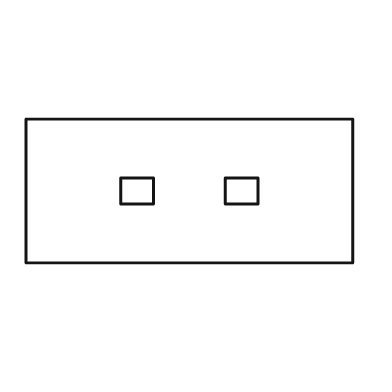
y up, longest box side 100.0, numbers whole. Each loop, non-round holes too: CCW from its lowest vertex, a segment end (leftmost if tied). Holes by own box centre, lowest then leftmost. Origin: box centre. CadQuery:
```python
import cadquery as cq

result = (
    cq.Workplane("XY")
    .moveTo(-50.0, -22.0)
    .lineTo(50.0, -22.0)
    .lineTo(50.0, 22.0)
    .lineTo(-50.0, 22.0)
    .close()
    .moveTo(-21.0, -4.0)
    .lineTo(-11.0, -4.0)
    .lineTo(-11.0, 4.0)
    .lineTo(-21.0, 4.0)
    .close()
    .moveTo(11.0, -4.0)
    .lineTo(21.0, -4.0)
    .lineTo(21.0, 4.0)
    .lineTo(11.0, 4.0)
    .close()
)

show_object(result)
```